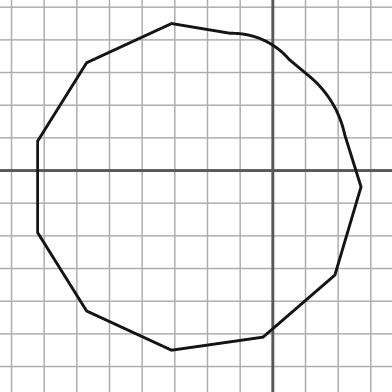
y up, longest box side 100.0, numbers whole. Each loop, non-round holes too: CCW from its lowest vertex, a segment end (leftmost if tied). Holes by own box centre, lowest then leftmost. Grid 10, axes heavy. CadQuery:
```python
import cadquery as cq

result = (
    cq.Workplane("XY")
    .moveTo(-31.0, -55.0)
    .lineTo(-3.0, -51.0)
    .lineTo(19.0, -32.0)
    .lineTo(27.0, -5.0)
    .lineTo(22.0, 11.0)
    .threePointArc((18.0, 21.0), (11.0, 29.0))
    .lineTo(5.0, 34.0)
    .threePointArc((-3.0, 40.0), (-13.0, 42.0))
    .lineTo(-31.0, 45.0)
    .lineTo(-57.0, 33.0)
    .lineTo(-72.0, 9.0)
    .lineTo(-72.0, -19.0)
    .lineTo(-57.0, -43.0)
    .close()
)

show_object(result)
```